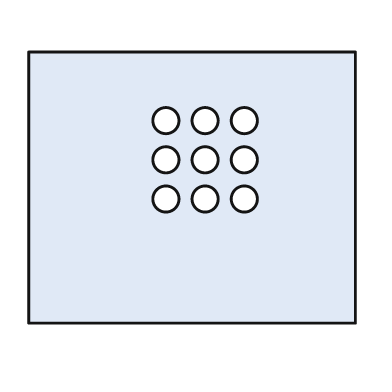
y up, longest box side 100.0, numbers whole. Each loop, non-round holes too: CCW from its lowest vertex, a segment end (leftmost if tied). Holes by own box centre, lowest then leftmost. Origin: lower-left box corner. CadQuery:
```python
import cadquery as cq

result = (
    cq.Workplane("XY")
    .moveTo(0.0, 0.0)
    .lineTo(100.0, 0.0)
    .lineTo(100.0, 83.0)
    .lineTo(0.0, 83.0)
    .close()
    .moveTo(42.0, 38.0)
    .circle(4.0)
    .moveTo(54.0, 38.0)
    .circle(4.0)
    .moveTo(66.0, 38.0)
    .circle(4.0)
    .moveTo(42.0, 50.0)
    .circle(4.0)
    .moveTo(54.0, 50.0)
    .circle(4.0)
    .moveTo(66.0, 50.0)
    .circle(4.0)
    .moveTo(42.0, 62.0)
    .circle(4.0)
    .moveTo(54.0, 62.0)
    .circle(4.0)
    .moveTo(66.0, 62.0)
    .circle(4.0)
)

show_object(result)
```